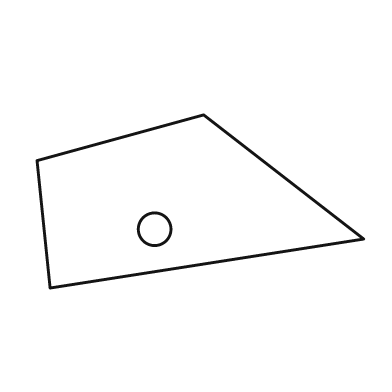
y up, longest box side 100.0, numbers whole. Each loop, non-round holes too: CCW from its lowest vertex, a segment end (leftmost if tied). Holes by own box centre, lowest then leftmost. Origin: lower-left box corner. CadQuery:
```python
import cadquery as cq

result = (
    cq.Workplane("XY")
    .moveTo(4.0, 0.0)
    .lineTo(100.0, 15.0)
    .lineTo(51.0, 53.0)
    .lineTo(0.0, 39.0)
    .close()
    .moveTo(36.0, 18.0)
    .circle(5.0)
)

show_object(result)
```